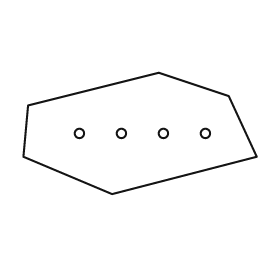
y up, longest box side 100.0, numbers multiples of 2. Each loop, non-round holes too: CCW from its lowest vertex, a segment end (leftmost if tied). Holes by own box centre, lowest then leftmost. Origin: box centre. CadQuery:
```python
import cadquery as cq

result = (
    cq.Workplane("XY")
    .moveTo(-12.0, -26.0)
    .lineTo(50.0, -10.0)
    .lineTo(38.0, 16.0)
    .lineTo(8.0, 26.0)
    .lineTo(-48.0, 12.0)
    .lineTo(-50.0, -10.0)
    .close()
    .moveTo(-26.0, 0.0)
    .circle(2.0)
    .moveTo(-8.0, 0.0)
    .circle(2.0)
    .moveTo(10.0, 0.0)
    .circle(2.0)
    .moveTo(28.0, 0.0)
    .circle(2.0)
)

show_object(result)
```